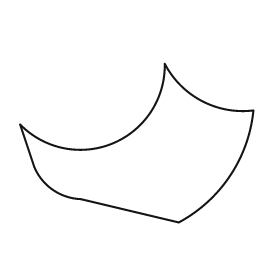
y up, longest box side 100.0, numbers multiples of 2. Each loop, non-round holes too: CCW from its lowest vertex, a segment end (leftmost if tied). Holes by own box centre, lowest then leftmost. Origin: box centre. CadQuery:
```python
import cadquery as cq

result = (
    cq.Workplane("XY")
    .moveTo(18.0, -34.0)
    .threePointArc((40.0, -14.0), (50.0, 14.0))
    .threePointArc((28.0, 18.0), (12.0, 34.0))
    .threePointArc((-10.0, 0.0), (-50.0, 8.0))
    .lineTo(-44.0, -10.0)
    .threePointArc((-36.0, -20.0), (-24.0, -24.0))
    .close()
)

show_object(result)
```